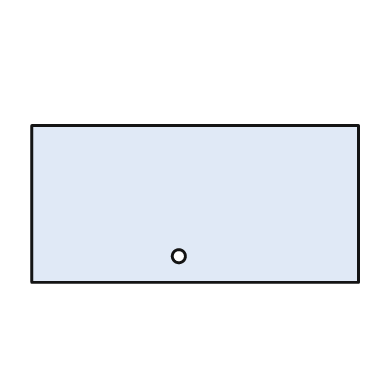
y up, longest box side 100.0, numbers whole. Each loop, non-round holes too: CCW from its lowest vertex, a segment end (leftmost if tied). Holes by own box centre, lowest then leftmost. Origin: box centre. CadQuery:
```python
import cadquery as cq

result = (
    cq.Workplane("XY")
    .moveTo(-50.0, -24.0)
    .lineTo(50.0, -24.0)
    .lineTo(50.0, 24.0)
    .lineTo(-50.0, 24.0)
    .close()
    .moveTo(-5.0, -16.0)
    .circle(2.0)
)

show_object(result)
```